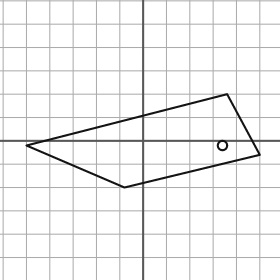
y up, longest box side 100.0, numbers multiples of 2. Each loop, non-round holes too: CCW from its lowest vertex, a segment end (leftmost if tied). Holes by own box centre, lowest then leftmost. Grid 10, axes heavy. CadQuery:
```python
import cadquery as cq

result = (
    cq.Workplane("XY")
    .moveTo(-8.0, -20.0)
    .lineTo(50.0, -6.0)
    .lineTo(36.0, 20.0)
    .lineTo(-50.0, -2.0)
    .close()
    .moveTo(34.0, -2.0)
    .circle(2.0)
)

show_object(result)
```